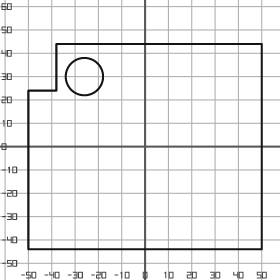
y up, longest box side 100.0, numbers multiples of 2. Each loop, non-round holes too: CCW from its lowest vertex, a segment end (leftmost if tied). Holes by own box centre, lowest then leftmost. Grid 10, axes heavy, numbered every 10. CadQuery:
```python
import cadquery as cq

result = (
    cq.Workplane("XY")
    .moveTo(-50.0, -44.0)
    .lineTo(50.0, -44.0)
    .lineTo(50.0, 44.0)
    .lineTo(-38.0, 44.0)
    .lineTo(-38.0, 24.0)
    .lineTo(-50.0, 24.0)
    .close()
    .moveTo(-26.0, 30.0)
    .circle(8.0)
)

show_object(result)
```